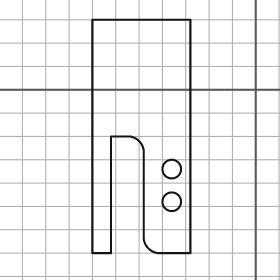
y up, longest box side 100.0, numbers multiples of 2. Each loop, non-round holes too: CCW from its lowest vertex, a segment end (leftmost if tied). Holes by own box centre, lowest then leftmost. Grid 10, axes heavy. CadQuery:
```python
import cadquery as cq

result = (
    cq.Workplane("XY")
    .moveTo(-70.0, -70.0)
    .lineTo(-62.0, -70.0)
    .lineTo(-62.0, -20.0)
    .lineTo(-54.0, -20.0)
    .threePointArc((-50.0, -22.0), (-48.0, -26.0))
    .lineTo(-48.0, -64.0)
    .threePointArc((-46.0, -68.0), (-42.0, -70.0))
    .lineTo(-28.0, -70.0)
    .lineTo(-28.0, 30.0)
    .lineTo(-70.0, 30.0)
    .close()
    .moveTo(-36.0, -48.0)
    .circle(4.0)
    .moveTo(-36.0, -34.0)
    .circle(4.0)
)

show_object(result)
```